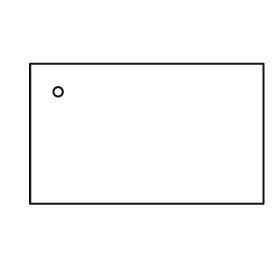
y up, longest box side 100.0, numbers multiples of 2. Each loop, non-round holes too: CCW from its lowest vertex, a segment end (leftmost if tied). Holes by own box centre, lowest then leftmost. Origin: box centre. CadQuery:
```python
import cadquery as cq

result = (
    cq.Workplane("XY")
    .moveTo(-50.0, -30.0)
    .lineTo(50.0, -30.0)
    .lineTo(50.0, 30.0)
    .lineTo(-50.0, 30.0)
    .close()
    .moveTo(-38.0, 18.0)
    .circle(2.0)
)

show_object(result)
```